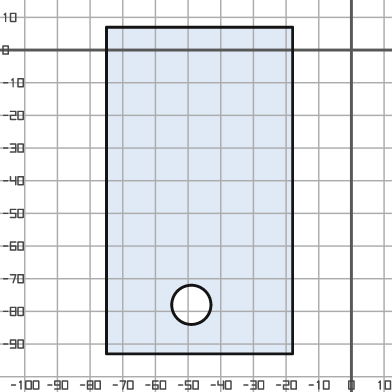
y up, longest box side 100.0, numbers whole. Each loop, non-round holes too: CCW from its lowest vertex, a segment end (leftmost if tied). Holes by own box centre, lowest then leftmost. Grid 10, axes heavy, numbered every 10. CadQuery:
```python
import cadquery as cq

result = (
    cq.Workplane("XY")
    .moveTo(-75.0, -93.0)
    .lineTo(-18.0, -93.0)
    .lineTo(-18.0, 7.0)
    .lineTo(-75.0, 7.0)
    .close()
    .moveTo(-49.0, -78.0)
    .circle(6.0)
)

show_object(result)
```